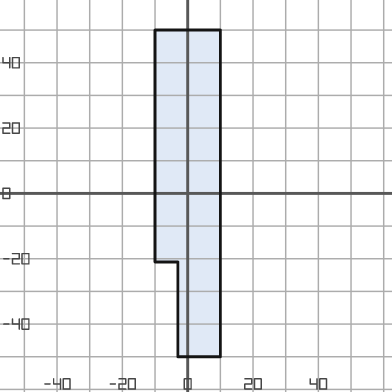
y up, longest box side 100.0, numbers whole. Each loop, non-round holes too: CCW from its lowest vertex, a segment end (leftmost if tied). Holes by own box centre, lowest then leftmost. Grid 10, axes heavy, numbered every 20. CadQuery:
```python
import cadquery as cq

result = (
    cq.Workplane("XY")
    .moveTo(-3.0, -50.0)
    .lineTo(10.0, -50.0)
    .lineTo(10.0, 50.0)
    .lineTo(-10.0, 50.0)
    .lineTo(-10.0, -21.0)
    .lineTo(-3.0, -21.0)
    .close()
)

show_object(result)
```